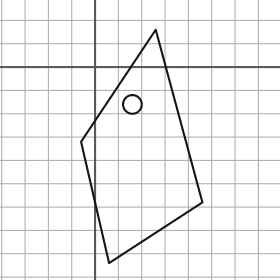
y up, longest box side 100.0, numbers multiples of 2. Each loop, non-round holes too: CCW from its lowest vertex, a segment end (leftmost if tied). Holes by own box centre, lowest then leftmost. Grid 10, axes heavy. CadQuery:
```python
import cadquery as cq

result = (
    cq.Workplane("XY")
    .moveTo(6.0, -84.0)
    .lineTo(46.0, -58.0)
    .lineTo(26.0, 16.0)
    .lineTo(-6.0, -32.0)
    .close()
    .moveTo(16.0, -16.0)
    .circle(4.0)
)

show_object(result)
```